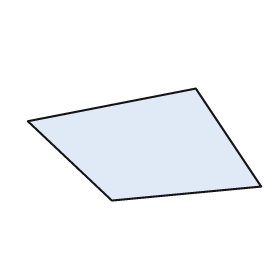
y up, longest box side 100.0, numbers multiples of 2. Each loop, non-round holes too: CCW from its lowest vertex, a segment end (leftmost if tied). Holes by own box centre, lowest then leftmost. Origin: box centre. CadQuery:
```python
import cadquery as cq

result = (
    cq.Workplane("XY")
    .moveTo(-14.0, -24.0)
    .lineTo(50.0, -18.0)
    .lineTo(22.0, 24.0)
    .lineTo(-50.0, 10.0)
    .close()
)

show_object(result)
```